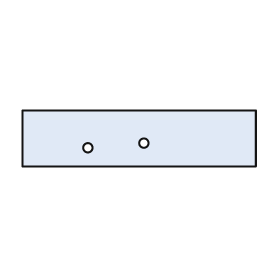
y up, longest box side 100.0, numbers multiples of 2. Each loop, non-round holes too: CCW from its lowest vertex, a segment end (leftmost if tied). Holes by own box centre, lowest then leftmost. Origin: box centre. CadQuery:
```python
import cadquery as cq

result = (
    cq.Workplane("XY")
    .moveTo(-50.0, -12.0)
    .lineTo(50.0, -12.0)
    .lineTo(50.0, 12.0)
    .lineTo(-50.0, 12.0)
    .close()
    .moveTo(-22.0, -4.0)
    .circle(2.0)
    .moveTo(2.0, -2.0)
    .circle(2.0)
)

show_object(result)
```